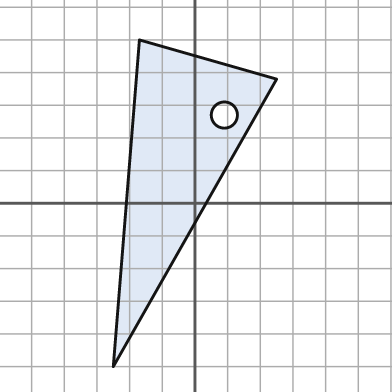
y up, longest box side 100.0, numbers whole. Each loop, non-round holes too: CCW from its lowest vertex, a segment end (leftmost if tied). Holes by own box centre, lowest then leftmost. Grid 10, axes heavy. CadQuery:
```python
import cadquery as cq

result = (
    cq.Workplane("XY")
    .moveTo(-25.0, -50.0)
    .lineTo(25.0, 38.0)
    .lineTo(-17.0, 50.0)
    .close()
    .moveTo(9.0, 27.0)
    .circle(4.0)
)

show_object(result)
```